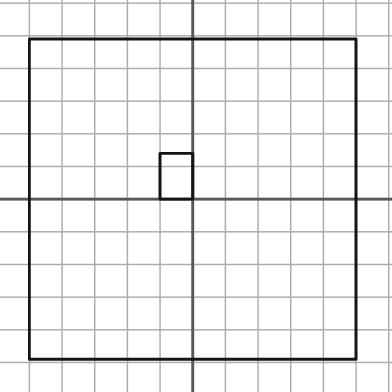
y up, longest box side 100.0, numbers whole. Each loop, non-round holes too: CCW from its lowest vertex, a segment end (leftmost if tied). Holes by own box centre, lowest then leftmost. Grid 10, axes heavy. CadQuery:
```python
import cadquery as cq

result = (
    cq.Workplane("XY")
    .moveTo(-50.0, -49.0)
    .lineTo(50.0, -49.0)
    .lineTo(50.0, 49.0)
    .lineTo(-50.0, 49.0)
    .close()
    .moveTo(-10.0, 0.0)
    .lineTo(0.0, 0.0)
    .lineTo(0.0, 14.0)
    .lineTo(-10.0, 14.0)
    .close()
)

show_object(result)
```